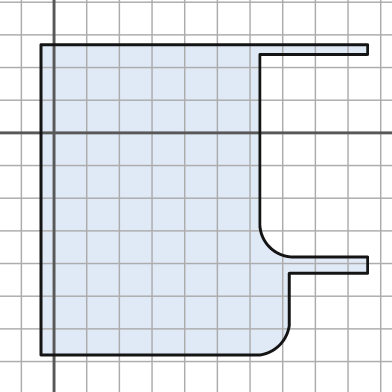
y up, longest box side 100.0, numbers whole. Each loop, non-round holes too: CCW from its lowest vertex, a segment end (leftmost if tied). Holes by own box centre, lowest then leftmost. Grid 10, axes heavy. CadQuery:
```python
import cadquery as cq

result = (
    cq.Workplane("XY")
    .moveTo(-4.0, -68.0)
    .lineTo(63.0, -68.0)
    .threePointArc((69.0, -65.0), (72.0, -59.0))
    .lineTo(72.0, -43.0)
    .lineTo(96.0, -43.0)
    .lineTo(96.0, -38.0)
    .lineTo(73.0, -38.0)
    .threePointArc((66.0, -35.0), (63.0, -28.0))
    .lineTo(63.0, 24.0)
    .lineTo(96.0, 24.0)
    .lineTo(96.0, 27.0)
    .lineTo(-4.0, 27.0)
    .close()
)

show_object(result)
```